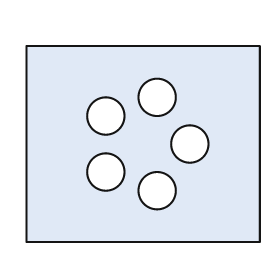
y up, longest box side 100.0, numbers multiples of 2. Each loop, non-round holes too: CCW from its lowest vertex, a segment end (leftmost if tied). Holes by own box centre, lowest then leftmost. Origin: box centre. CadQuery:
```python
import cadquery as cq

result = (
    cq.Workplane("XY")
    .moveTo(-50.0, -42.0)
    .lineTo(50.0, -42.0)
    .lineTo(50.0, 42.0)
    .lineTo(-50.0, 42.0)
    .close()
    .moveTo(6.0, -20.0)
    .circle(8.0)
    .moveTo(-16.0, -12.0)
    .circle(8.0)
    .moveTo(20.0, 0.0)
    .circle(8.0)
    .moveTo(-16.0, 12.0)
    .circle(8.0)
    .moveTo(6.0, 20.0)
    .circle(8.0)
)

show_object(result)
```